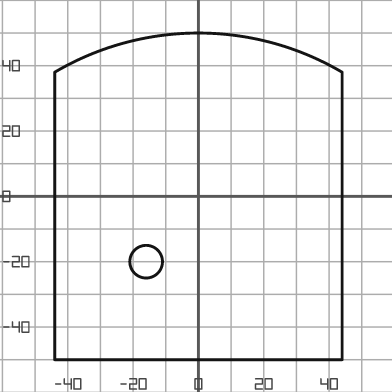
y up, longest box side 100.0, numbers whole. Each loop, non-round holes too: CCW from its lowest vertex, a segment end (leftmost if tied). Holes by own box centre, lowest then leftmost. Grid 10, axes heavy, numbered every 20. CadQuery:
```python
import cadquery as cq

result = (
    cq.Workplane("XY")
    .moveTo(-44.0, -50.0)
    .lineTo(44.0, -50.0)
    .lineTo(44.0, 38.0)
    .threePointArc((0.0, 50.0), (-44.0, 38.0))
    .close()
    .moveTo(-16.0, -20.0)
    .circle(5.0)
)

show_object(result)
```